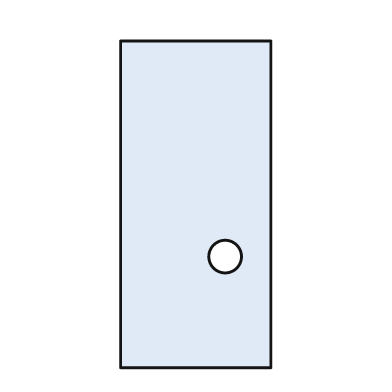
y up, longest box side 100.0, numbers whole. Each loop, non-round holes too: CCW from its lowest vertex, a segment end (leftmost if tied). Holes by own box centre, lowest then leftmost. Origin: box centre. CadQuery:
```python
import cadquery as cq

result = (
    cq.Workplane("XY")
    .moveTo(-23.0, -50.0)
    .lineTo(23.0, -50.0)
    .lineTo(23.0, 50.0)
    .lineTo(-23.0, 50.0)
    .close()
    .moveTo(9.0, -16.0)
    .circle(5.0)
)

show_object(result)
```